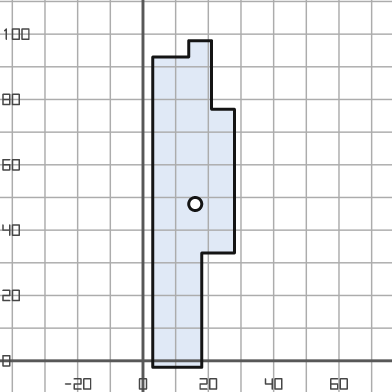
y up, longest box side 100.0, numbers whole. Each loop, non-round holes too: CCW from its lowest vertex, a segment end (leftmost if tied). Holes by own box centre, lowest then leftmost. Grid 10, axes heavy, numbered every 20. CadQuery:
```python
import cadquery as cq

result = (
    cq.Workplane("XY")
    .moveTo(3.0, -2.0)
    .lineTo(18.0, -2.0)
    .lineTo(18.0, 33.0)
    .lineTo(28.0, 33.0)
    .lineTo(28.0, 77.0)
    .lineTo(21.0, 77.0)
    .lineTo(21.0, 98.0)
    .lineTo(14.0, 98.0)
    .lineTo(14.0, 93.0)
    .lineTo(3.0, 93.0)
    .close()
    .moveTo(16.0, 48.0)
    .circle(2.0)
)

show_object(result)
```